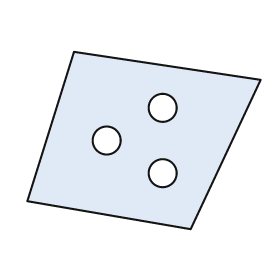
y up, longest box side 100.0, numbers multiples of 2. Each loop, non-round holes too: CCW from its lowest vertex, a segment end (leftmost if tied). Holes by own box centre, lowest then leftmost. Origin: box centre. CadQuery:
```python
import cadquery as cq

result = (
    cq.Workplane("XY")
    .moveTo(20.0, -38.0)
    .lineTo(50.0, 26.0)
    .lineTo(-30.0, 38.0)
    .lineTo(-50.0, -26.0)
    .close()
    .moveTo(8.0, -14.0)
    .circle(6.0)
    .moveTo(-16.0, 0.0)
    .circle(6.0)
    .moveTo(8.0, 14.0)
    .circle(6.0)
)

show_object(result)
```